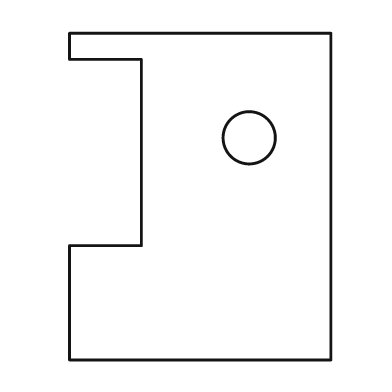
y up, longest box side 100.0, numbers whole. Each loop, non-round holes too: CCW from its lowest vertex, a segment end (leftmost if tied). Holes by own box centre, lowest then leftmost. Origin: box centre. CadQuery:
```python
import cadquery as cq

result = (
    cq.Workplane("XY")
    .moveTo(-40.0, -50.0)
    .lineTo(40.0, -50.0)
    .lineTo(40.0, 50.0)
    .lineTo(-40.0, 50.0)
    .lineTo(-40.0, 42.0)
    .lineTo(-18.0, 42.0)
    .lineTo(-18.0, -15.0)
    .lineTo(-40.0, -15.0)
    .close()
    .moveTo(15.0, 18.0)
    .circle(8.0)
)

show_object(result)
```